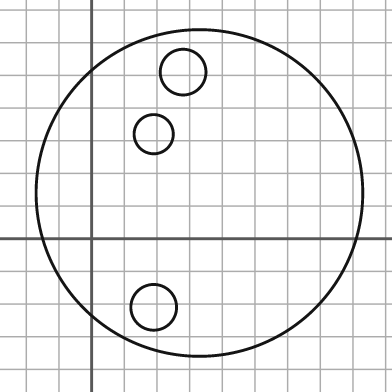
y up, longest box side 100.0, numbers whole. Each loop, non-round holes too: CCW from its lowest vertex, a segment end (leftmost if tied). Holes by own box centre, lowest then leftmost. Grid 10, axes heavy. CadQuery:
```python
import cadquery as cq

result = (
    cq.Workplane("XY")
    .moveTo(33.0, 14.0)
    .circle(50.0)
    .moveTo(19.0, -21.0)
    .circle(7.0)
    .moveTo(19.0, 32.0)
    .circle(6.0)
    .moveTo(28.0, 51.0)
    .circle(7.0)
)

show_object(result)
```